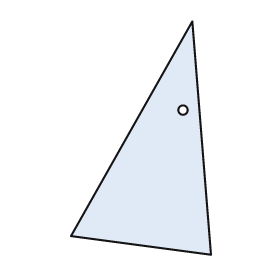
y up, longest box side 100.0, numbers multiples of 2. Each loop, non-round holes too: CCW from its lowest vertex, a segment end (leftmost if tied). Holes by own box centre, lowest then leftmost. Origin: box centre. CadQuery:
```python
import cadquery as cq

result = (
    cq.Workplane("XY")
    .moveTo(30.0, -50.0)
    .lineTo(22.0, 50.0)
    .lineTo(-30.0, -42.0)
    .close()
    .moveTo(18.0, 12.0)
    .circle(2.0)
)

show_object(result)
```